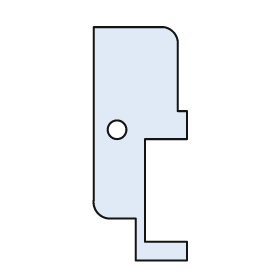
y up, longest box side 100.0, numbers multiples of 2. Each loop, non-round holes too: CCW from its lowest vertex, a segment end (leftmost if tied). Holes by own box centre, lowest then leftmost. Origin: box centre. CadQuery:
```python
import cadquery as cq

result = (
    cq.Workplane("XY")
    .moveTo(-2.0, -50.0)
    .lineTo(20.0, -50.0)
    .lineTo(20.0, -42.0)
    .lineTo(2.0, -42.0)
    .lineTo(2.0, 2.0)
    .lineTo(20.0, 2.0)
    .lineTo(20.0, 14.0)
    .lineTo(16.0, 14.0)
    .lineTo(16.0, 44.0)
    .threePointArc((14.0, 48.0), (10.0, 50.0))
    .lineTo(-20.0, 50.0)
    .lineTo(-20.0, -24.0)
    .threePointArc((-18.0, -30.0), (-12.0, -32.0))
    .lineTo(-2.0, -32.0)
    .close()
    .moveTo(-10.0, 6.0)
    .circle(4.0)
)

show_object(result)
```